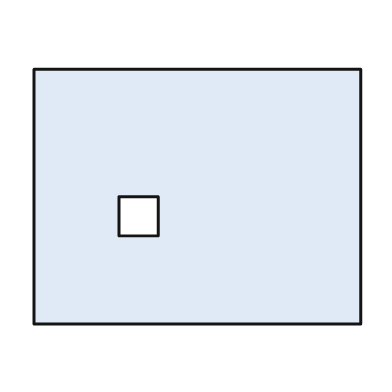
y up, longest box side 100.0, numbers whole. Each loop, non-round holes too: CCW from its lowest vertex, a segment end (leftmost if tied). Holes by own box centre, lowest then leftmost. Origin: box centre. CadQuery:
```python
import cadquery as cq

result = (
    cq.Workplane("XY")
    .moveTo(-50.0, -39.0)
    .lineTo(50.0, -39.0)
    .lineTo(50.0, 39.0)
    .lineTo(-50.0, 39.0)
    .close()
    .moveTo(-24.0, -12.0)
    .lineTo(-12.0, -12.0)
    .lineTo(-12.0, 0.0)
    .lineTo(-24.0, 0.0)
    .close()
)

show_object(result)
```